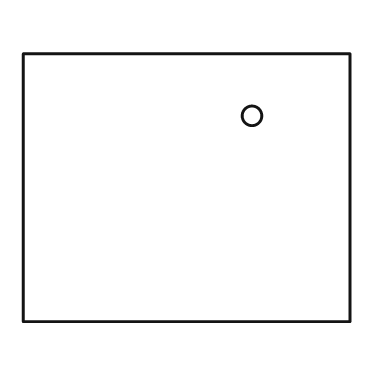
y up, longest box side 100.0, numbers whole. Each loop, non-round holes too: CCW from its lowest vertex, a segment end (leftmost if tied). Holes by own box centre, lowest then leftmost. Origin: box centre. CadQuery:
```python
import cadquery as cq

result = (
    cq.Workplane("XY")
    .moveTo(-50.0, -41.0)
    .lineTo(50.0, -41.0)
    .lineTo(50.0, 41.0)
    .lineTo(-50.0, 41.0)
    .close()
    .moveTo(20.0, 22.0)
    .circle(3.0)
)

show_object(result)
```